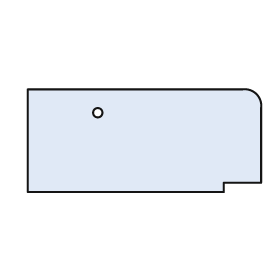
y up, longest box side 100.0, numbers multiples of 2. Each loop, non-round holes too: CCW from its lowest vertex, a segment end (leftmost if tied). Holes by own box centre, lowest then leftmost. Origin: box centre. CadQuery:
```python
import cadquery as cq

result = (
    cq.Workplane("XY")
    .moveTo(-50.0, -22.0)
    .lineTo(34.0, -22.0)
    .lineTo(34.0, -18.0)
    .lineTo(50.0, -18.0)
    .lineTo(50.0, 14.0)
    .threePointArc((48.0, 20.0), (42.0, 22.0))
    .lineTo(-50.0, 22.0)
    .close()
    .moveTo(-20.0, 12.0)
    .circle(2.0)
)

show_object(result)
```